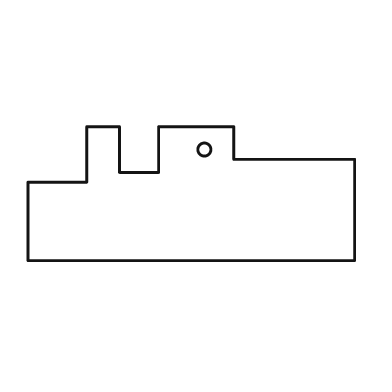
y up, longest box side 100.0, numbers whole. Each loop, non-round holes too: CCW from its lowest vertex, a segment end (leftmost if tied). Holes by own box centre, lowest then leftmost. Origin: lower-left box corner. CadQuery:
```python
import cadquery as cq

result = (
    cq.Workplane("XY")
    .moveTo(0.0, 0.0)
    .lineTo(100.0, 0.0)
    .lineTo(100.0, 31.0)
    .lineTo(63.0, 31.0)
    .lineTo(63.0, 41.0)
    .lineTo(40.0, 41.0)
    .lineTo(40.0, 27.0)
    .lineTo(28.0, 27.0)
    .lineTo(28.0, 41.0)
    .lineTo(18.0, 41.0)
    .lineTo(18.0, 24.0)
    .lineTo(0.0, 24.0)
    .close()
    .moveTo(54.0, 34.0)
    .circle(2.0)
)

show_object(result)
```